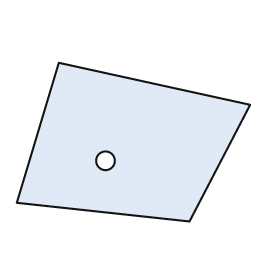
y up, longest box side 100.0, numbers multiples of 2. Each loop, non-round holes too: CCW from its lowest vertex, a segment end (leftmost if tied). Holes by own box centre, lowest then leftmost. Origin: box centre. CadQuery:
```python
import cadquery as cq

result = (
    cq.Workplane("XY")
    .moveTo(24.0, -34.0)
    .lineTo(50.0, 16.0)
    .lineTo(-32.0, 34.0)
    .lineTo(-50.0, -26.0)
    .close()
    .moveTo(-12.0, -8.0)
    .circle(4.0)
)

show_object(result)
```